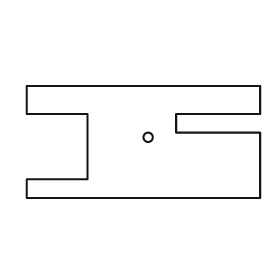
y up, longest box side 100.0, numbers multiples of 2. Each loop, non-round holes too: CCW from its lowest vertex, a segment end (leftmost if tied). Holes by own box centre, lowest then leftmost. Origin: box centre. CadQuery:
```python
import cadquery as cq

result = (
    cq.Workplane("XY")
    .moveTo(-50.0, -24.0)
    .lineTo(50.0, -24.0)
    .lineTo(50.0, 4.0)
    .lineTo(14.0, 4.0)
    .lineTo(14.0, 12.0)
    .lineTo(50.0, 12.0)
    .lineTo(50.0, 24.0)
    .lineTo(-50.0, 24.0)
    .lineTo(-50.0, 12.0)
    .lineTo(-24.0, 12.0)
    .lineTo(-24.0, -16.0)
    .lineTo(-50.0, -16.0)
    .close()
    .moveTo(2.0, 2.0)
    .circle(2.0)
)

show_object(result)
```